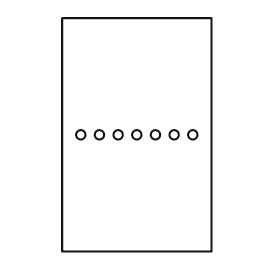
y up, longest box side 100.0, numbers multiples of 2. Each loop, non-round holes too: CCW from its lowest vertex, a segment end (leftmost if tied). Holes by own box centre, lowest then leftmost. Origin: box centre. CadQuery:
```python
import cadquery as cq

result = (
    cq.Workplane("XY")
    .moveTo(-32.0, -50.0)
    .lineTo(32.0, -50.0)
    .lineTo(32.0, 50.0)
    .lineTo(-32.0, 50.0)
    .close()
    .moveTo(-24.0, 0.0)
    .circle(2.0)
    .moveTo(-16.0, 0.0)
    .circle(2.0)
    .moveTo(-8.0, 0.0)
    .circle(2.0)
    .moveTo(0.0, 0.0)
    .circle(2.0)
    .moveTo(8.0, 0.0)
    .circle(2.0)
    .moveTo(16.0, 0.0)
    .circle(2.0)
    .moveTo(24.0, 0.0)
    .circle(2.0)
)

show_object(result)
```